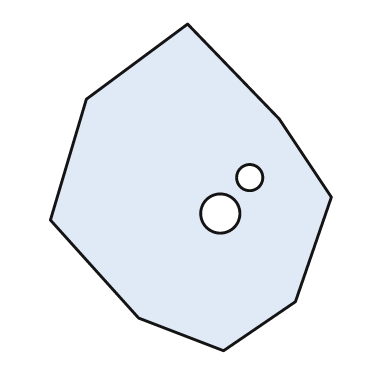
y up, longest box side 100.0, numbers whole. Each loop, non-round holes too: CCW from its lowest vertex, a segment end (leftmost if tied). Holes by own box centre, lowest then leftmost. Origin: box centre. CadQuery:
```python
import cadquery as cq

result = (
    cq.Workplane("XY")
    .moveTo(10.0, -50.0)
    .lineTo(32.0, -35.0)
    .lineTo(43.0, -3.0)
    .lineTo(27.0, 21.0)
    .lineTo(-1.0, 50.0)
    .lineTo(-32.0, 27.0)
    .lineTo(-43.0, -10.0)
    .lineTo(-16.0, -40.0)
    .close()
    .moveTo(9.0, -8.0)
    .circle(6.0)
    .moveTo(18.0, 3.0)
    .circle(4.0)
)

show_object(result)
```